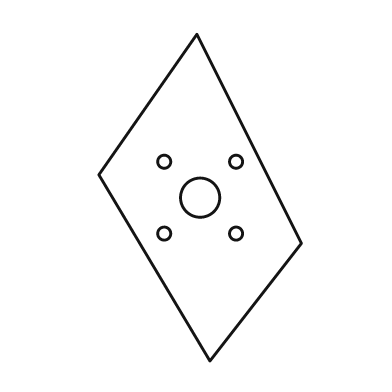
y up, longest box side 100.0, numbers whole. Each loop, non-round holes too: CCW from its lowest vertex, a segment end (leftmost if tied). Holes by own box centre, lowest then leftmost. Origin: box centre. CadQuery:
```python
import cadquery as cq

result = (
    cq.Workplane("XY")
    .moveTo(3.0, -50.0)
    .lineTo(31.0, -14.0)
    .lineTo(-1.0, 50.0)
    .lineTo(-31.0, 7.0)
    .close()
    .moveTo(-11.0, -11.0)
    .circle(2.0)
    .moveTo(11.0, -11.0)
    .circle(2.0)
    .moveTo(0.0, 0.0)
    .circle(6.0)
    .moveTo(-11.0, 11.0)
    .circle(2.0)
    .moveTo(11.0, 11.0)
    .circle(2.0)
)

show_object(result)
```